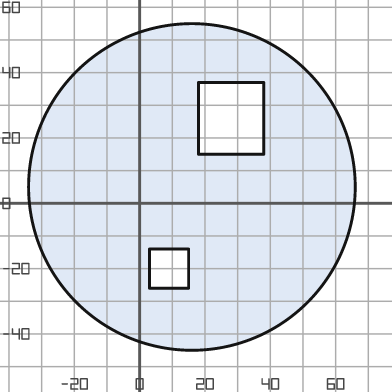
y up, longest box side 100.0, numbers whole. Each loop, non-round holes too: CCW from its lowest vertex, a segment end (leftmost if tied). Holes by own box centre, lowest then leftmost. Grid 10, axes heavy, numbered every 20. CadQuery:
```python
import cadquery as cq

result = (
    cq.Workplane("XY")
    .moveTo(16.0, 5.0)
    .circle(50.0)
    .moveTo(3.0, -26.0)
    .lineTo(15.0, -26.0)
    .lineTo(15.0, -14.0)
    .lineTo(3.0, -14.0)
    .close()
    .moveTo(18.0, 15.0)
    .lineTo(38.0, 15.0)
    .lineTo(38.0, 37.0)
    .lineTo(18.0, 37.0)
    .close()
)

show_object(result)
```